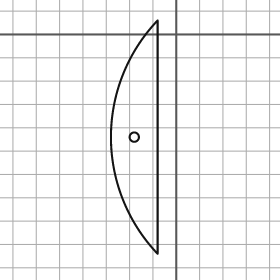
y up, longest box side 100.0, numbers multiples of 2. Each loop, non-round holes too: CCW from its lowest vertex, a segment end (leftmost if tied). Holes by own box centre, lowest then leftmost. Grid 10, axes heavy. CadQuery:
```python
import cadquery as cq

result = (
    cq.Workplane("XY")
    .moveTo(-8.0, -94.0)
    .lineTo(-8.0, 6.0)
    .threePointArc((-28.0, -44.0), (-8.0, -94.0))
    .close()
    .moveTo(-18.0, -44.0)
    .circle(2.0)
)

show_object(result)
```